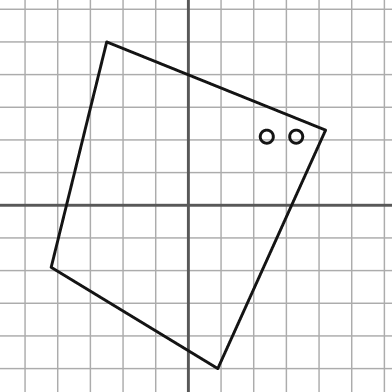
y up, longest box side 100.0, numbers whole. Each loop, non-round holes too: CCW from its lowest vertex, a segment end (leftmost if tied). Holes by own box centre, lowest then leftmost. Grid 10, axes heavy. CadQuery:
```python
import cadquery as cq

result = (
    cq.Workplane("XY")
    .moveTo(9.0, -50.0)
    .lineTo(42.0, 23.0)
    .lineTo(-25.0, 50.0)
    .lineTo(-42.0, -19.0)
    .close()
    .moveTo(24.0, 21.0)
    .circle(2.0)
    .moveTo(33.0, 21.0)
    .circle(2.0)
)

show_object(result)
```